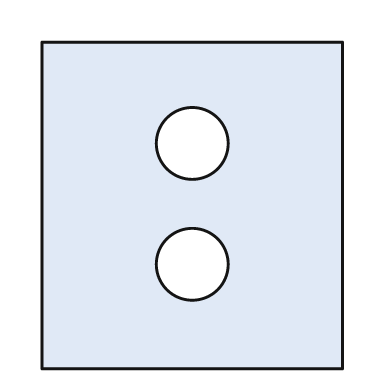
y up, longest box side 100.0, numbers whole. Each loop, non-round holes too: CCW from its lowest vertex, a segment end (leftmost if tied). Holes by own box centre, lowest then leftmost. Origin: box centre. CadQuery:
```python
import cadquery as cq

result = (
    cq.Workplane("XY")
    .moveTo(-46.0, -50.0)
    .lineTo(46.0, -50.0)
    .lineTo(46.0, 50.0)
    .lineTo(-46.0, 50.0)
    .close()
    .moveTo(0.0, -18.0)
    .circle(11.0)
    .moveTo(0.0, 19.0)
    .circle(11.0)
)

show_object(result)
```